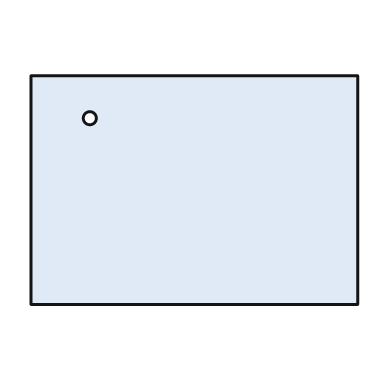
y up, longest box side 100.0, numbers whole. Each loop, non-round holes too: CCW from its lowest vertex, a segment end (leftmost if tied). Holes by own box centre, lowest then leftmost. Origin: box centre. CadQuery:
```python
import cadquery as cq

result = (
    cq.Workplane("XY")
    .moveTo(-50.0, -35.0)
    .lineTo(50.0, -35.0)
    .lineTo(50.0, 35.0)
    .lineTo(-50.0, 35.0)
    .close()
    .moveTo(-32.0, 22.0)
    .circle(2.0)
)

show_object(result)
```